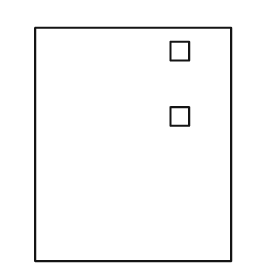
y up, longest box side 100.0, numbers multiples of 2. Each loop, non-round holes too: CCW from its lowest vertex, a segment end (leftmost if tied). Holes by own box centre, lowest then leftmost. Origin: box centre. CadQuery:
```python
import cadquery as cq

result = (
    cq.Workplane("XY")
    .moveTo(-42.0, -50.0)
    .lineTo(42.0, -50.0)
    .lineTo(42.0, 50.0)
    .lineTo(-42.0, 50.0)
    .close()
    .moveTo(16.0, 8.0)
    .lineTo(24.0, 8.0)
    .lineTo(24.0, 16.0)
    .lineTo(16.0, 16.0)
    .close()
    .moveTo(16.0, 36.0)
    .lineTo(24.0, 36.0)
    .lineTo(24.0, 44.0)
    .lineTo(16.0, 44.0)
    .close()
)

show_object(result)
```